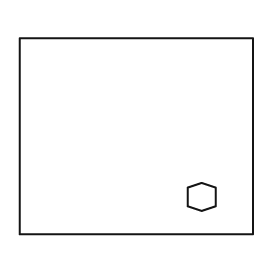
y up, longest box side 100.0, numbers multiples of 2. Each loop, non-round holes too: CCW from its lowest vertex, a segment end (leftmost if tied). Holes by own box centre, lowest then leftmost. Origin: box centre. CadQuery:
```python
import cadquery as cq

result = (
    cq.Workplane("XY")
    .moveTo(-50.0, -42.0)
    .lineTo(50.0, -42.0)
    .lineTo(50.0, 42.0)
    .lineTo(-50.0, 42.0)
    .close()
    .moveTo(28.0, -32.0)
    .lineTo(34.0, -30.0)
    .lineTo(34.0, -22.0)
    .lineTo(28.0, -20.0)
    .lineTo(22.0, -22.0)
    .lineTo(22.0, -30.0)
    .close()
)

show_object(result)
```